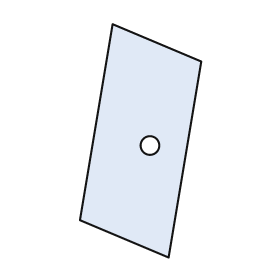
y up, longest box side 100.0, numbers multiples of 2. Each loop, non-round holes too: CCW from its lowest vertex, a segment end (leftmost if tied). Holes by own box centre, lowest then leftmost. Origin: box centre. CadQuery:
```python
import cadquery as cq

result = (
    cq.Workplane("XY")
    .moveTo(12.0, -50.0)
    .lineTo(26.0, 34.0)
    .lineTo(-12.0, 50.0)
    .lineTo(-26.0, -34.0)
    .close()
    .moveTo(4.0, -2.0)
    .circle(4.0)
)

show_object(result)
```